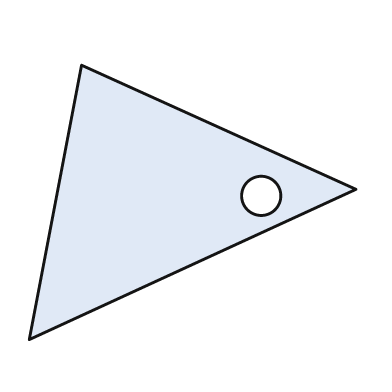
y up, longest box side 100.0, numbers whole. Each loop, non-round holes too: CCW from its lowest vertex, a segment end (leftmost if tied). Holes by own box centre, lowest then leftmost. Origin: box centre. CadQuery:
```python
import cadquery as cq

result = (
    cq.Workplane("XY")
    .moveTo(-50.0, -42.0)
    .lineTo(50.0, 4.0)
    .lineTo(-34.0, 42.0)
    .close()
    .moveTo(21.0, 2.0)
    .circle(6.0)
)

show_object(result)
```